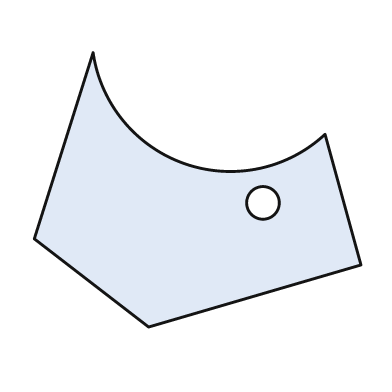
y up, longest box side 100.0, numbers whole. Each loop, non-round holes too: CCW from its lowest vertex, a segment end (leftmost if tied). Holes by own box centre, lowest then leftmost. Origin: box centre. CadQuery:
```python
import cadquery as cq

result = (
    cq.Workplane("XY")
    .moveTo(-15.0, -42.0)
    .lineTo(50.0, -23.0)
    .lineTo(39.0, 17.0)
    .threePointArc((-4.0, 8.0), (-32.0, 42.0))
    .lineTo(-50.0, -15.0)
    .close()
    .moveTo(20.0, -4.0)
    .circle(5.0)
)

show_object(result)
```